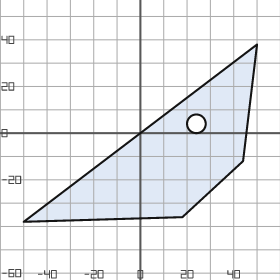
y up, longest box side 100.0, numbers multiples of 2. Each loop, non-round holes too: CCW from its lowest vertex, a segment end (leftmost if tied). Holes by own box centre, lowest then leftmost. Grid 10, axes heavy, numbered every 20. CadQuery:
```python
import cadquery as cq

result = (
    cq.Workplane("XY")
    .moveTo(-50.0, -38.0)
    .lineTo(18.0, -36.0)
    .lineTo(44.0, -12.0)
    .lineTo(50.0, 38.0)
    .close()
    .moveTo(24.0, 4.0)
    .circle(4.0)
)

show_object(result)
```